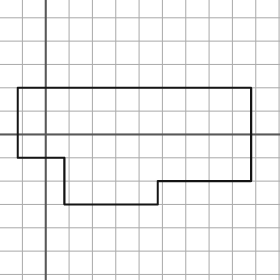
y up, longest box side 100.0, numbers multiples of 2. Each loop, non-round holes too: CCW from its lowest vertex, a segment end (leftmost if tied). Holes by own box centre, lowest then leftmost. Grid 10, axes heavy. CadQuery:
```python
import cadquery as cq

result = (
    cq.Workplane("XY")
    .moveTo(8.0, -30.0)
    .lineTo(48.0, -30.0)
    .lineTo(48.0, -20.0)
    .lineTo(88.0, -20.0)
    .lineTo(88.0, 20.0)
    .lineTo(-12.0, 20.0)
    .lineTo(-12.0, -10.0)
    .lineTo(8.0, -10.0)
    .close()
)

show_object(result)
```